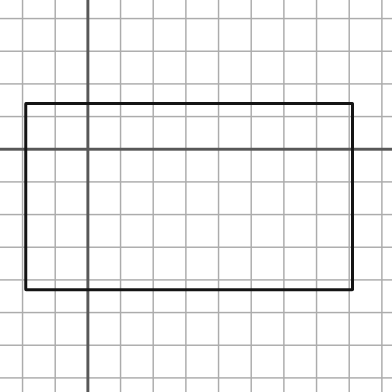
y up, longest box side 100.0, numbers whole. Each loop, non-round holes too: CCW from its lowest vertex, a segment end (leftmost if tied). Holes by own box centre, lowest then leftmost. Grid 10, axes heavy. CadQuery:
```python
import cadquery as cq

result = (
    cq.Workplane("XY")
    .moveTo(-19.0, -43.0)
    .lineTo(81.0, -43.0)
    .lineTo(81.0, 14.0)
    .lineTo(-19.0, 14.0)
    .close()
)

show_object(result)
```